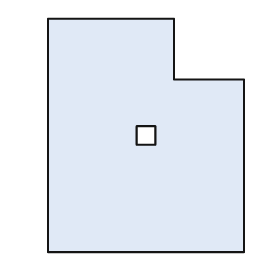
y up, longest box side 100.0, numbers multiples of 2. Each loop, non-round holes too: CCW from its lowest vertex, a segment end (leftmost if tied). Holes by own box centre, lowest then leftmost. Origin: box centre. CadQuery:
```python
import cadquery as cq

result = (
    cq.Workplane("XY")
    .moveTo(-42.0, -50.0)
    .lineTo(42.0, -50.0)
    .lineTo(42.0, 24.0)
    .lineTo(12.0, 24.0)
    .lineTo(12.0, 50.0)
    .lineTo(-42.0, 50.0)
    .close()
    .moveTo(-4.0, -4.0)
    .lineTo(4.0, -4.0)
    .lineTo(4.0, 4.0)
    .lineTo(-4.0, 4.0)
    .close()
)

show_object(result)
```